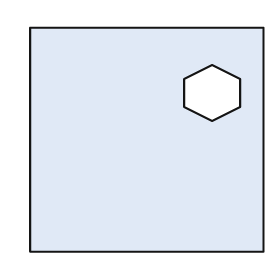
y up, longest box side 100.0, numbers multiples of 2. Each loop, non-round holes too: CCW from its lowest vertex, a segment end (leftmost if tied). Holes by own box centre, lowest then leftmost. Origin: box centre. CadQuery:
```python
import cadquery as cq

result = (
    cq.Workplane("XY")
    .moveTo(-50.0, -48.0)
    .lineTo(50.0, -48.0)
    .lineTo(50.0, 48.0)
    .lineTo(-50.0, 48.0)
    .close()
    .moveTo(28.0, 8.0)
    .lineTo(40.0, 14.0)
    .lineTo(40.0, 26.0)
    .lineTo(28.0, 32.0)
    .lineTo(16.0, 26.0)
    .lineTo(16.0, 14.0)
    .close()
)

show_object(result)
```